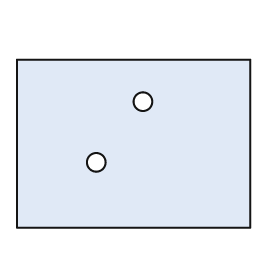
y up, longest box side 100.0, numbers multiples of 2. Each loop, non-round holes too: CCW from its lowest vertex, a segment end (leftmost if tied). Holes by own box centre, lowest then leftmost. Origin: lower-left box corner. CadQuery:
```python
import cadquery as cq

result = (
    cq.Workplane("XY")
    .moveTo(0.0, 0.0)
    .lineTo(100.0, 0.0)
    .lineTo(100.0, 72.0)
    .lineTo(0.0, 72.0)
    .close()
    .moveTo(34.0, 28.0)
    .circle(4.0)
    .moveTo(54.0, 54.0)
    .circle(4.0)
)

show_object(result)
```